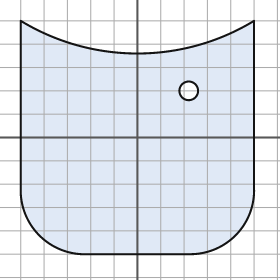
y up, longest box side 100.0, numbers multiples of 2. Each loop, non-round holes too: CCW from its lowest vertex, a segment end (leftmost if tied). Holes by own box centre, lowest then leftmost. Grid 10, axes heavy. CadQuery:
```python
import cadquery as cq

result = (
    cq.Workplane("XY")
    .moveTo(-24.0, -50.0)
    .lineTo(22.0, -50.0)
    .threePointArc((42.0, -42.0), (50.0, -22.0))
    .lineTo(50.0, 50.0)
    .threePointArc((0.0, 36.0), (-50.0, 50.0))
    .lineTo(-50.0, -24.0)
    .threePointArc((-42.0, -42.0), (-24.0, -50.0))
    .close()
    .moveTo(22.0, 20.0)
    .circle(4.0)
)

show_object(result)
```